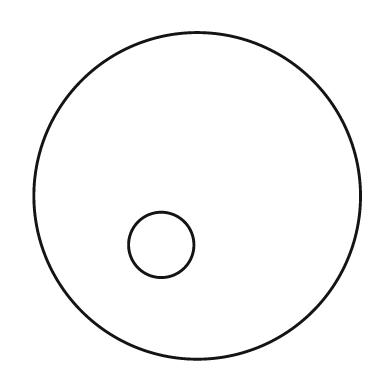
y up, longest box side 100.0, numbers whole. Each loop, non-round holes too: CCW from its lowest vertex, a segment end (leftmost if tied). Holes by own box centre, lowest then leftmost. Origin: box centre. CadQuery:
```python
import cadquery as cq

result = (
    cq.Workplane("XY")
    .moveTo(0.0, 0.0)
    .circle(50.0)
    .moveTo(-11.0, -15.0)
    .circle(10.0)
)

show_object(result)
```